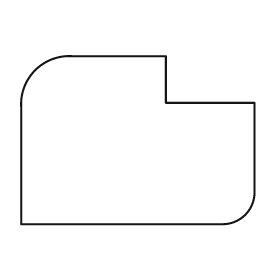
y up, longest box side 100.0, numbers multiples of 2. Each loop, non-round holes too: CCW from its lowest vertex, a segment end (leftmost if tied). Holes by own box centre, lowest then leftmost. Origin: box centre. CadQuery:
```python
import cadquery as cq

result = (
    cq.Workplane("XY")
    .moveTo(-50.0, -36.0)
    .lineTo(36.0, -36.0)
    .threePointArc((46.0, -32.0), (50.0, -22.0))
    .lineTo(50.0, 16.0)
    .lineTo(12.0, 16.0)
    .lineTo(12.0, 36.0)
    .lineTo(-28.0, 36.0)
    .threePointArc((-44.0, 30.0), (-50.0, 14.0))
    .close()
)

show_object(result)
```